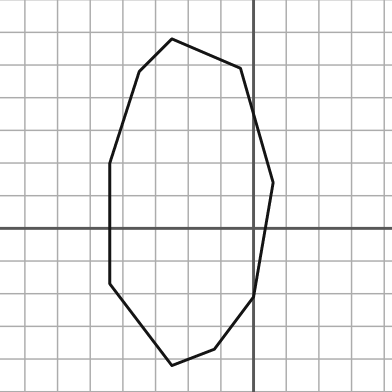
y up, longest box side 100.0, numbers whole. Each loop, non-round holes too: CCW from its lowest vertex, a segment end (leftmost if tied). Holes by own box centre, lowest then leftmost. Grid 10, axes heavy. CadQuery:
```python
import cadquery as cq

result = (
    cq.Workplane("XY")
    .moveTo(-25.0, -42.0)
    .lineTo(-12.0, -37.0)
    .lineTo(0.0, -21.0)
    .lineTo(6.0, 14.0)
    .lineTo(-4.0, 49.0)
    .lineTo(-25.0, 58.0)
    .lineTo(-35.0, 48.0)
    .lineTo(-44.0, 20.0)
    .lineTo(-44.0, -17.0)
    .close()
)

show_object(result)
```